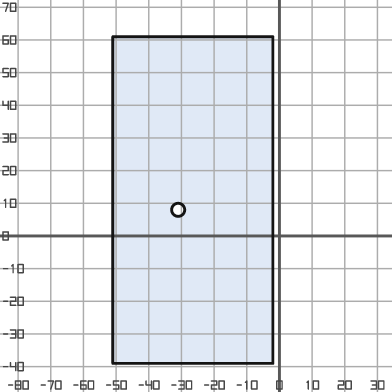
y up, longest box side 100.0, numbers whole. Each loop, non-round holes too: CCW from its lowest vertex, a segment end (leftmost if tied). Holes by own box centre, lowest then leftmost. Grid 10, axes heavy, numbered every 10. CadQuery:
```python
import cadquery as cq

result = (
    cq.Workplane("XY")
    .moveTo(-51.0, -39.0)
    .lineTo(-2.0, -39.0)
    .lineTo(-2.0, 61.0)
    .lineTo(-51.0, 61.0)
    .close()
    .moveTo(-31.0, 8.0)
    .circle(2.0)
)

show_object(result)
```